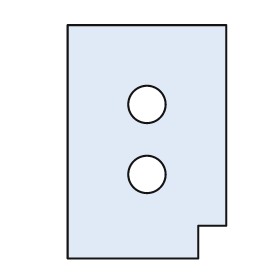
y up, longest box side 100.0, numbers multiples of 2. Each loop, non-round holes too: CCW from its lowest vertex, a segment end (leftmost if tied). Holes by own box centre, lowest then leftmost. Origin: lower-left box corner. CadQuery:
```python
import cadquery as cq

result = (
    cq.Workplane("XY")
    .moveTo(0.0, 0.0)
    .lineTo(56.0, 0.0)
    .lineTo(56.0, 14.0)
    .lineTo(68.0, 14.0)
    .lineTo(68.0, 100.0)
    .lineTo(0.0, 100.0)
    .close()
    .moveTo(34.0, 36.0)
    .circle(8.0)
    .moveTo(34.0, 66.0)
    .circle(8.0)
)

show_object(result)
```